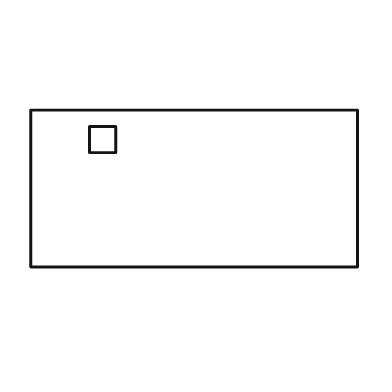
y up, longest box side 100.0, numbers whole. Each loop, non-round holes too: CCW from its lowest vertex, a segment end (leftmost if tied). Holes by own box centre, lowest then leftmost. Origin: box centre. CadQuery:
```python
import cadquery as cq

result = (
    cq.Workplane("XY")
    .moveTo(-50.0, -24.0)
    .lineTo(50.0, -24.0)
    .lineTo(50.0, 24.0)
    .lineTo(-50.0, 24.0)
    .close()
    .moveTo(-32.0, 11.0)
    .lineTo(-24.0, 11.0)
    .lineTo(-24.0, 19.0)
    .lineTo(-32.0, 19.0)
    .close()
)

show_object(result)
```